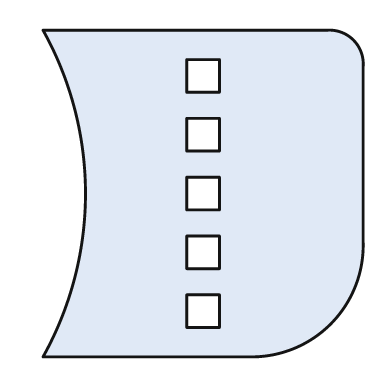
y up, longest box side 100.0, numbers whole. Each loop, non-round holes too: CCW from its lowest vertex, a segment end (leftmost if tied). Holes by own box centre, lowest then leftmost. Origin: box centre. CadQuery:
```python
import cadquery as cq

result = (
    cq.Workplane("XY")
    .moveTo(-49.0, -50.0)
    .lineTo(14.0, -50.0)
    .threePointArc((39.0, -40.0), (49.0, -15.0))
    .lineTo(49.0, 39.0)
    .threePointArc((46.0, 47.0), (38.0, 50.0))
    .lineTo(-49.0, 50.0)
    .threePointArc((-36.0, 0.0), (-49.0, -50.0))
    .close()
    .moveTo(-5.0, -41.0)
    .lineTo(5.0, -41.0)
    .lineTo(5.0, -31.0)
    .lineTo(-5.0, -31.0)
    .close()
    .moveTo(-5.0, -23.0)
    .lineTo(5.0, -23.0)
    .lineTo(5.0, -13.0)
    .lineTo(-5.0, -13.0)
    .close()
    .moveTo(-5.0, -5.0)
    .lineTo(5.0, -5.0)
    .lineTo(5.0, 5.0)
    .lineTo(-5.0, 5.0)
    .close()
    .moveTo(-5.0, 13.0)
    .lineTo(5.0, 13.0)
    .lineTo(5.0, 23.0)
    .lineTo(-5.0, 23.0)
    .close()
    .moveTo(-5.0, 31.0)
    .lineTo(5.0, 31.0)
    .lineTo(5.0, 41.0)
    .lineTo(-5.0, 41.0)
    .close()
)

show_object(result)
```